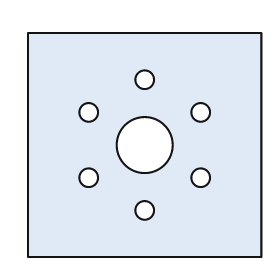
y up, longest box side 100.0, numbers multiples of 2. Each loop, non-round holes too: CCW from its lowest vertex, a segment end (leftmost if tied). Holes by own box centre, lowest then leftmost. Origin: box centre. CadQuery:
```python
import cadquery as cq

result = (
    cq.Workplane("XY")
    .moveTo(-50.0, -48.0)
    .lineTo(50.0, -48.0)
    .lineTo(50.0, 48.0)
    .lineTo(-50.0, 48.0)
    .close()
    .moveTo(0.0, -28.0)
    .circle(4.0)
    .moveTo(-24.0, -14.0)
    .circle(4.0)
    .moveTo(24.0, -14.0)
    .circle(4.0)
    .moveTo(0.0, 0.0)
    .circle(12.0)
    .moveTo(-24.0, 14.0)
    .circle(4.0)
    .moveTo(24.0, 14.0)
    .circle(4.0)
    .moveTo(0.0, 28.0)
    .circle(4.0)
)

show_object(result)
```